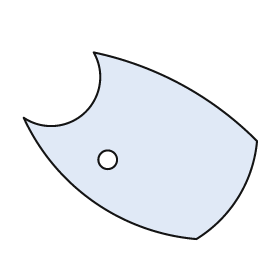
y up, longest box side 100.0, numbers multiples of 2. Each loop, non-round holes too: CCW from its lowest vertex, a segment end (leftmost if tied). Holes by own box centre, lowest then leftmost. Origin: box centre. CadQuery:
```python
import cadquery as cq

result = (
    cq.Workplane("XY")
    .moveTo(24.0, -40.0)
    .threePointArc((42.0, -22.0), (50.0, 2.0))
    .threePointArc((18.0, 26.0), (-20.0, 40.0))
    .threePointArc((-24.0, 14.0), (-50.0, 12.0))
    .threePointArc((-20.0, -24.0), (24.0, -40.0))
    .close()
    .moveTo(-14.0, -6.0)
    .circle(4.0)
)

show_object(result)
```